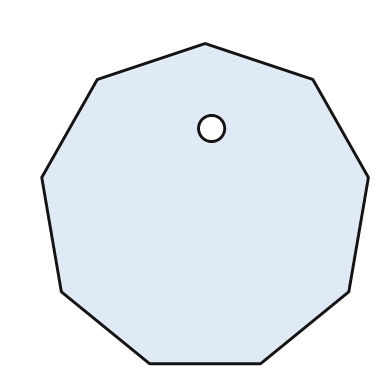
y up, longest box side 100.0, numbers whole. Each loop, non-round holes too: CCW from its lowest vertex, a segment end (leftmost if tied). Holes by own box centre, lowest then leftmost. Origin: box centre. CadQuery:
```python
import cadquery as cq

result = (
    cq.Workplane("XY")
    .moveTo(-17.0, -49.0)
    .lineTo(17.0, -49.0)
    .lineTo(44.0, -27.0)
    .lineTo(50.0, 8.0)
    .lineTo(33.0, 38.0)
    .lineTo(0.0, 49.0)
    .lineTo(-33.0, 38.0)
    .lineTo(-50.0, 8.0)
    .lineTo(-44.0, -27.0)
    .close()
    .moveTo(2.0, 23.0)
    .circle(4.0)
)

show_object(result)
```